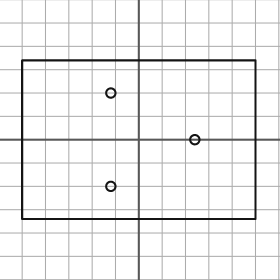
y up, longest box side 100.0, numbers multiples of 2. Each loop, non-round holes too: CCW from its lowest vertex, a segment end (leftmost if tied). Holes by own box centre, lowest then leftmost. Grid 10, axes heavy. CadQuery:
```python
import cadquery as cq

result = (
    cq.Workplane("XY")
    .moveTo(-50.0, -34.0)
    .lineTo(50.0, -34.0)
    .lineTo(50.0, 34.0)
    .lineTo(-50.0, 34.0)
    .close()
    .moveTo(-12.0, -20.0)
    .circle(2.0)
    .moveTo(24.0, 0.0)
    .circle(2.0)
    .moveTo(-12.0, 20.0)
    .circle(2.0)
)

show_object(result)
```